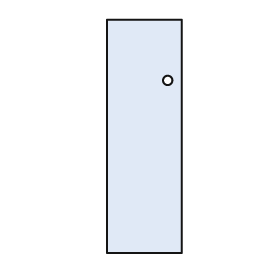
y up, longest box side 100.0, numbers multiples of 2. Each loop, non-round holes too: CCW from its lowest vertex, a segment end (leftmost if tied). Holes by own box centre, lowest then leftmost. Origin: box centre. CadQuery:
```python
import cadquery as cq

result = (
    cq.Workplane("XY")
    .moveTo(-16.0, -50.0)
    .lineTo(16.0, -50.0)
    .lineTo(16.0, 50.0)
    .lineTo(-16.0, 50.0)
    .close()
    .moveTo(10.0, 24.0)
    .circle(2.0)
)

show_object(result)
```